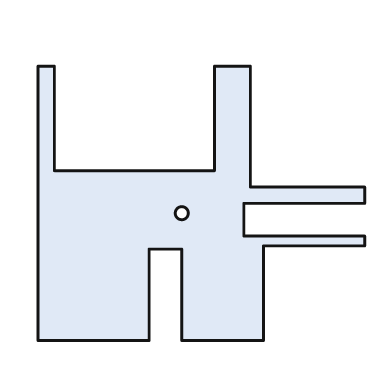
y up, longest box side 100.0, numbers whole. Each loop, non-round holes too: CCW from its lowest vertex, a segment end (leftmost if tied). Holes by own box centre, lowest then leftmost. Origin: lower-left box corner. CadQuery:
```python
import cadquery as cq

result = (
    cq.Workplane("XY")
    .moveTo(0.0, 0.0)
    .lineTo(34.0, 0.0)
    .lineTo(34.0, 28.0)
    .lineTo(44.0, 28.0)
    .lineTo(44.0, 0.0)
    .lineTo(69.0, 0.0)
    .lineTo(69.0, 29.0)
    .lineTo(100.0, 29.0)
    .lineTo(100.0, 32.0)
    .lineTo(63.0, 32.0)
    .lineTo(63.0, 42.0)
    .lineTo(100.0, 42.0)
    .lineTo(100.0, 47.0)
    .lineTo(65.0, 47.0)
    .lineTo(65.0, 84.0)
    .lineTo(54.0, 84.0)
    .lineTo(54.0, 52.0)
    .lineTo(5.0, 52.0)
    .lineTo(5.0, 84.0)
    .lineTo(0.0, 84.0)
    .close()
    .moveTo(44.0, 39.0)
    .circle(2.0)
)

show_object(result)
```